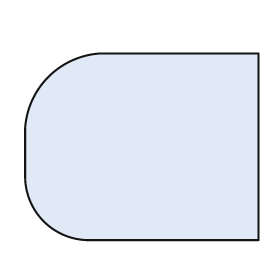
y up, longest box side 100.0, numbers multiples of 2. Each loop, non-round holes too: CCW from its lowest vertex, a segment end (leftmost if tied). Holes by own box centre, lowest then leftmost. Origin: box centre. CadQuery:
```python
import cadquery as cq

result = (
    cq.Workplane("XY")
    .moveTo(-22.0, -40.0)
    .lineTo(50.0, -40.0)
    .lineTo(50.0, 40.0)
    .lineTo(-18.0, 40.0)
    .threePointArc((-40.0, 30.0), (-50.0, 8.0))
    .lineTo(-50.0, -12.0)
    .threePointArc((-42.0, -32.0), (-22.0, -40.0))
    .close()
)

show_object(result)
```